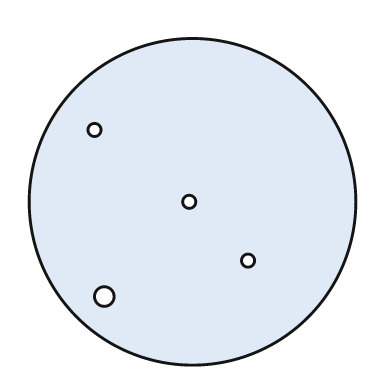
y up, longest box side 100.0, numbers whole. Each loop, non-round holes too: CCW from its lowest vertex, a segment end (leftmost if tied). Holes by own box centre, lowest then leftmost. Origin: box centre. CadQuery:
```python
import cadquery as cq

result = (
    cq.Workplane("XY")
    .moveTo(0.0, 0.0)
    .circle(50.0)
    .moveTo(-27.0, -29.0)
    .circle(3.0)
    .moveTo(17.0, -18.0)
    .circle(2.0)
    .moveTo(-1.0, 0.0)
    .circle(2.0)
    .moveTo(-30.0, 22.0)
    .circle(2.0)
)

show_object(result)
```